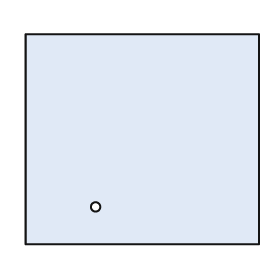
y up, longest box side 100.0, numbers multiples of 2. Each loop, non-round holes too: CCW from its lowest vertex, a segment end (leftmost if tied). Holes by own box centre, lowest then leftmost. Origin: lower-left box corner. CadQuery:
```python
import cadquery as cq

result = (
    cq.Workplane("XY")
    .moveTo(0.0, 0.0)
    .lineTo(100.0, 0.0)
    .lineTo(100.0, 90.0)
    .lineTo(0.0, 90.0)
    .close()
    .moveTo(30.0, 16.0)
    .circle(2.0)
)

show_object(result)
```